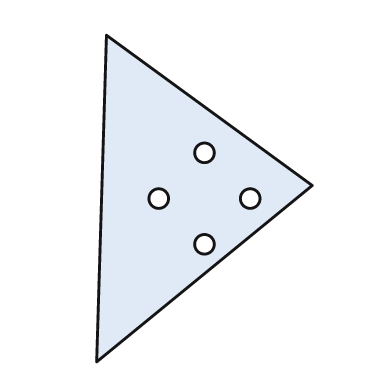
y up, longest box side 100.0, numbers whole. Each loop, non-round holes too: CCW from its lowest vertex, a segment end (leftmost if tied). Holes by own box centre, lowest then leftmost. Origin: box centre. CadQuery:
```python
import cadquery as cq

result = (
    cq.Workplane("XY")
    .moveTo(-33.0, -50.0)
    .lineTo(33.0, 4.0)
    .lineTo(-30.0, 50.0)
    .close()
    .moveTo(0.0, -14.0)
    .circle(3.0)
    .moveTo(-14.0, 0.0)
    .circle(3.0)
    .moveTo(14.0, 0.0)
    .circle(3.0)
    .moveTo(0.0, 14.0)
    .circle(3.0)
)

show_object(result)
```